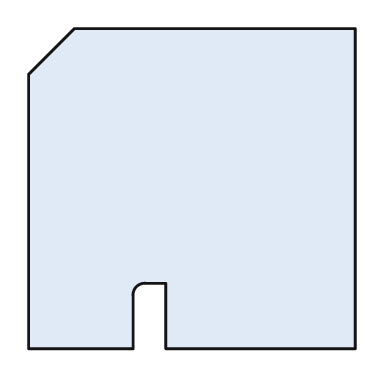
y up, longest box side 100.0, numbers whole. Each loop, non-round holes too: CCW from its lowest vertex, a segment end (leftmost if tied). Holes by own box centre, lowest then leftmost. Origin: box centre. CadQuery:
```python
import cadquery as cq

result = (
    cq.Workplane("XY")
    .moveTo(-50.0, -49.0)
    .lineTo(-18.0, -49.0)
    .lineTo(-18.0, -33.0)
    .threePointArc((-17.0, -30.0), (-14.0, -29.0))
    .lineTo(-8.0, -29.0)
    .lineTo(-8.0, -49.0)
    .lineTo(50.0, -49.0)
    .lineTo(50.0, 49.0)
    .lineTo(-36.0, 49.0)
    .lineTo(-50.0, 35.0)
    .close()
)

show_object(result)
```